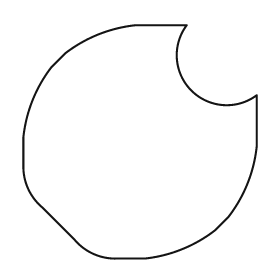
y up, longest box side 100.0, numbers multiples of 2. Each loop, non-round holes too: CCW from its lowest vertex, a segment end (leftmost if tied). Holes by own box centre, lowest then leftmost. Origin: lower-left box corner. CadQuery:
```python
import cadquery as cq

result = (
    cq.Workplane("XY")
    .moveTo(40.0, 0.0)
    .lineTo(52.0, 0.0)
    .threePointArc((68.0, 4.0), (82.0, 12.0))
    .lineTo(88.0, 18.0)
    .threePointArc((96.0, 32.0), (100.0, 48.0))
    .lineTo(100.0, 70.0)
    .threePointArc((72.0, 72.0), (70.0, 100.0))
    .lineTo(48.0, 100.0)
    .threePointArc((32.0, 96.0), (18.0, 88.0))
    .lineTo(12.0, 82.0)
    .threePointArc((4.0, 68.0), (0.0, 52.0))
    .lineTo(0.0, 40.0)
    .threePointArc((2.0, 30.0), (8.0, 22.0))
    .lineTo(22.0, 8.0)
    .threePointArc((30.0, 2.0), (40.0, 0.0))
    .close()
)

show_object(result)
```